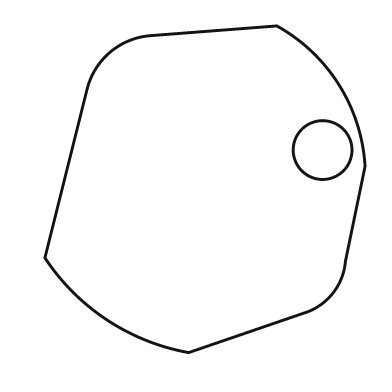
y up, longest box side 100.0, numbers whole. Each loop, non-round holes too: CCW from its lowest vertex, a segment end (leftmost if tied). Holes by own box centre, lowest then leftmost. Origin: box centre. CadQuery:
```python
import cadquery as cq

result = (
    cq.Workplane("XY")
    .moveTo(-5.0, -50.0)
    .lineTo(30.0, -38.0)
    .threePointArc((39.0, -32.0), (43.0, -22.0))
    .lineTo(49.0, 7.0)
    .threePointArc((41.0, 32.0), (22.0, 50.0))
    .lineTo(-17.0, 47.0)
    .threePointArc((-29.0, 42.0), (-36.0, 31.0))
    .lineTo(-49.0, -21.0)
    .threePointArc((-30.0, -40.0), (-5.0, -50.0))
    .close()
    .moveTo(36.0, 12.0)
    .circle(9.0)
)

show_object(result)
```